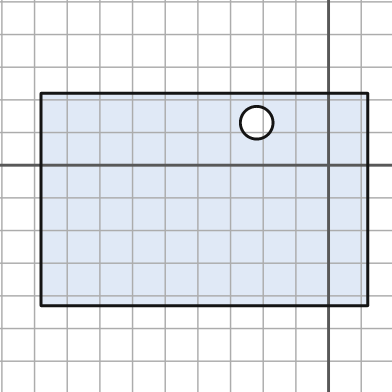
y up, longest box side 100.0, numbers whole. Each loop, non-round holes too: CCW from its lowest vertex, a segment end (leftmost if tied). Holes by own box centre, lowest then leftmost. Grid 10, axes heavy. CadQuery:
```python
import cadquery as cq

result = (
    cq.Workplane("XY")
    .moveTo(-88.0, -43.0)
    .lineTo(12.0, -43.0)
    .lineTo(12.0, 22.0)
    .lineTo(-88.0, 22.0)
    .close()
    .moveTo(-22.0, 13.0)
    .circle(5.0)
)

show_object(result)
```